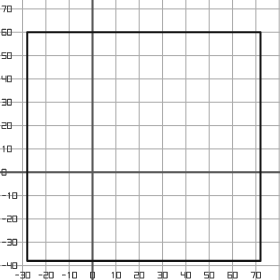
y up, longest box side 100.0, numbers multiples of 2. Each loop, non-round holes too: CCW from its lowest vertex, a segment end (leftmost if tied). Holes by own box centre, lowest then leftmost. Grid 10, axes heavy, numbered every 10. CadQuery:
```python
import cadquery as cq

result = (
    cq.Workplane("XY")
    .moveTo(-28.0, -38.0)
    .lineTo(72.0, -38.0)
    .lineTo(72.0, 60.0)
    .lineTo(-28.0, 60.0)
    .close()
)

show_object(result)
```